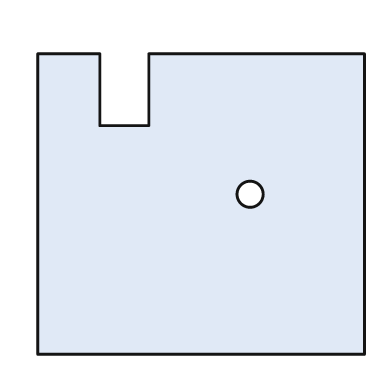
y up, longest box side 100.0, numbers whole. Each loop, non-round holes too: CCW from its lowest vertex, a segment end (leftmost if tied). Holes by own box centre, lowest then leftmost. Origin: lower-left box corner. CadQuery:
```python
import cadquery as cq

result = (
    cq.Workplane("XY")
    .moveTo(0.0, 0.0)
    .lineTo(100.0, 0.0)
    .lineTo(100.0, 92.0)
    .lineTo(34.0, 92.0)
    .lineTo(34.0, 70.0)
    .lineTo(19.0, 70.0)
    .lineTo(19.0, 92.0)
    .lineTo(0.0, 92.0)
    .close()
    .moveTo(65.0, 49.0)
    .circle(4.0)
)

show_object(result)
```